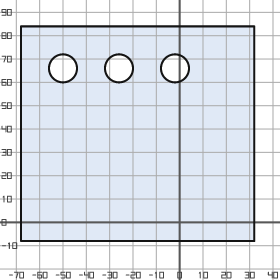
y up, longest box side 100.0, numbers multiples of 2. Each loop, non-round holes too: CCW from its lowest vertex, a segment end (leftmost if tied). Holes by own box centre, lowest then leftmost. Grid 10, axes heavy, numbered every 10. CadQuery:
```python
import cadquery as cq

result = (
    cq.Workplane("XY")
    .moveTo(-68.0, -8.0)
    .lineTo(32.0, -8.0)
    .lineTo(32.0, 84.0)
    .lineTo(-68.0, 84.0)
    .close()
    .moveTo(-50.0, 66.0)
    .circle(6.0)
    .moveTo(-26.0, 66.0)
    .circle(6.0)
    .moveTo(-2.0, 66.0)
    .circle(6.0)
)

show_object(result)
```